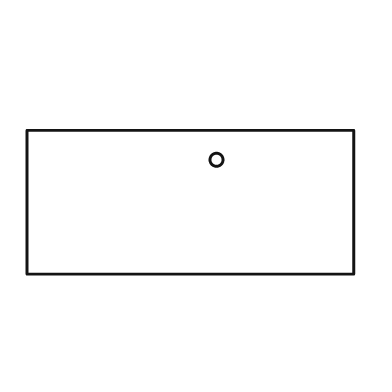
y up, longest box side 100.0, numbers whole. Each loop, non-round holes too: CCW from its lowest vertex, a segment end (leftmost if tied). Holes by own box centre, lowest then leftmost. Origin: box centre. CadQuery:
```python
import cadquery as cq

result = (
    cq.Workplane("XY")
    .moveTo(-50.0, -22.0)
    .lineTo(50.0, -22.0)
    .lineTo(50.0, 22.0)
    .lineTo(-50.0, 22.0)
    .close()
    .moveTo(8.0, 13.0)
    .circle(2.0)
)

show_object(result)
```